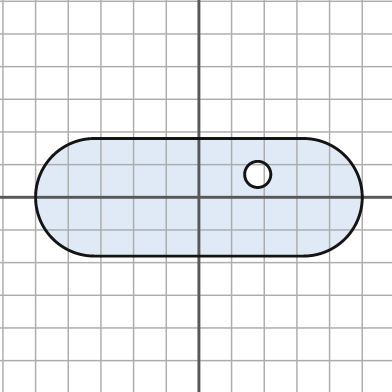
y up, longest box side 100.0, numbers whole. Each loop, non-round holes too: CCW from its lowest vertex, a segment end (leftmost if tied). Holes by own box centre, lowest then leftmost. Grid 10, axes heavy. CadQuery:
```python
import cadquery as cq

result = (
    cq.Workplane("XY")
    .moveTo(-32.0, -18.0)
    .lineTo(32.0, -18.0)
    .threePointArc((50.0, 0.0), (32.0, 18.0))
    .lineTo(-32.0, 18.0)
    .threePointArc((-50.0, 0.0), (-32.0, -18.0))
    .close()
    .moveTo(18.0, 7.0)
    .circle(4.0)
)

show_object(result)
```